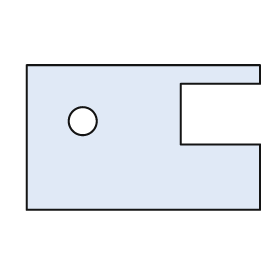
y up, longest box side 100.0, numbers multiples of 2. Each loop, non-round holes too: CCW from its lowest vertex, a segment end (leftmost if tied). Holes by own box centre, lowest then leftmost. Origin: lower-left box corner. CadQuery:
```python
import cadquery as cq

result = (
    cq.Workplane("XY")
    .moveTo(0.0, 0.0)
    .lineTo(100.0, 0.0)
    .lineTo(100.0, 28.0)
    .lineTo(66.0, 28.0)
    .lineTo(66.0, 54.0)
    .lineTo(100.0, 54.0)
    .lineTo(100.0, 62.0)
    .lineTo(0.0, 62.0)
    .close()
    .moveTo(24.0, 38.0)
    .circle(6.0)
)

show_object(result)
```